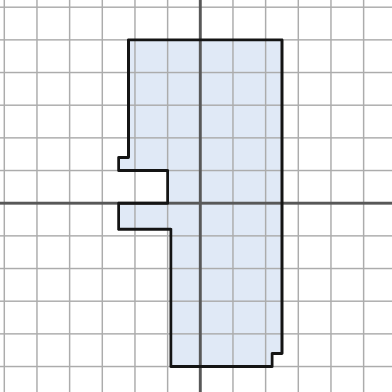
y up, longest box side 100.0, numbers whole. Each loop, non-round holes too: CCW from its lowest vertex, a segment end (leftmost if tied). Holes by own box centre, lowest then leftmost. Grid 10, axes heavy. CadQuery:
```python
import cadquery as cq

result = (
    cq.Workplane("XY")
    .moveTo(-9.0, -50.0)
    .lineTo(22.0, -50.0)
    .lineTo(22.0, -46.0)
    .lineTo(25.0, -46.0)
    .lineTo(25.0, 50.0)
    .lineTo(-22.0, 50.0)
    .lineTo(-22.0, 14.0)
    .lineTo(-25.0, 14.0)
    .lineTo(-25.0, 10.0)
    .lineTo(-10.0, 10.0)
    .lineTo(-10.0, 0.0)
    .lineTo(-25.0, 0.0)
    .lineTo(-25.0, -8.0)
    .lineTo(-9.0, -8.0)
    .close()
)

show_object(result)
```